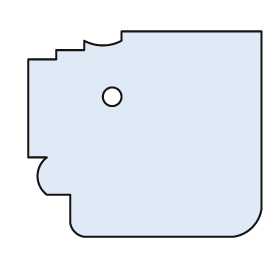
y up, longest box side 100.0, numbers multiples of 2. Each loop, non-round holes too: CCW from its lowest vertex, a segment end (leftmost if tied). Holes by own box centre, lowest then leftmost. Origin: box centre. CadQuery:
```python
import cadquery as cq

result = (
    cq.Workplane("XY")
    .moveTo(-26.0, -44.0)
    .lineTo(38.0, -44.0)
    .threePointArc((46.0, -40.0), (50.0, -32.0))
    .lineTo(50.0, 44.0)
    .lineTo(-10.0, 44.0)
    .lineTo(-10.0, 40.0)
    .threePointArc((-18.0, 38.0), (-26.0, 40.0))
    .lineTo(-26.0, 36.0)
    .lineTo(-38.0, 36.0)
    .lineTo(-38.0, 32.0)
    .lineTo(-50.0, 32.0)
    .lineTo(-50.0, -10.0)
    .lineTo(-42.0, -10.0)
    .threePointArc((-46.0, -18.0), (-42.0, -26.0))
    .lineTo(-32.0, -26.0)
    .lineTo(-32.0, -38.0)
    .threePointArc((-30.0, -42.0), (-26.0, -44.0))
    .close()
    .moveTo(-14.0, 16.0)
    .circle(4.0)
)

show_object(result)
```